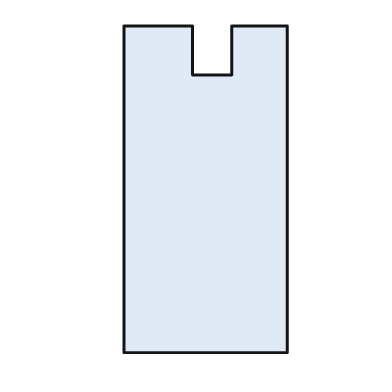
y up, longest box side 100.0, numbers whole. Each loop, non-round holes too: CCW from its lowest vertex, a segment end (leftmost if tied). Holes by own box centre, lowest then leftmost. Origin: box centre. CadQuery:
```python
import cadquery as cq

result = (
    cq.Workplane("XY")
    .moveTo(-25.0, -50.0)
    .lineTo(25.0, -50.0)
    .lineTo(25.0, 50.0)
    .lineTo(8.0, 50.0)
    .lineTo(8.0, 35.0)
    .lineTo(-4.0, 35.0)
    .lineTo(-4.0, 50.0)
    .lineTo(-25.0, 50.0)
    .close()
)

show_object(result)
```